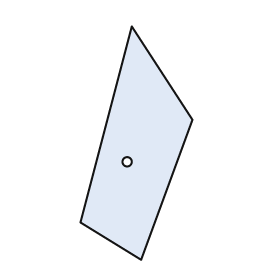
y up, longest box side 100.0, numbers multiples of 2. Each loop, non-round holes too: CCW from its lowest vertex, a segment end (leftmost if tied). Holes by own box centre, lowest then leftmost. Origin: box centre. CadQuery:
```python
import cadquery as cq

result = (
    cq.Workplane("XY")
    .moveTo(2.0, -50.0)
    .lineTo(24.0, 10.0)
    .lineTo(-2.0, 50.0)
    .lineTo(-24.0, -34.0)
    .close()
    .moveTo(-4.0, -8.0)
    .circle(2.0)
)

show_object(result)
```